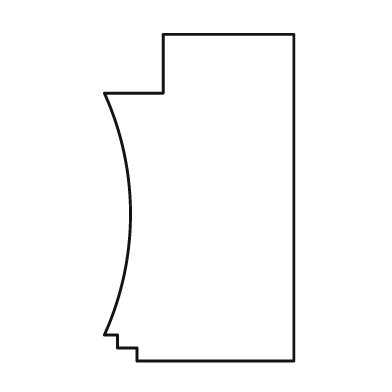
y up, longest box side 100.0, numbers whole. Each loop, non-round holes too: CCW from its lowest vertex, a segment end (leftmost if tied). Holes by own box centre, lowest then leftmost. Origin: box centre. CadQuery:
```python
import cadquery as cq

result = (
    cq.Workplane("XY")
    .moveTo(-19.0, -50.0)
    .lineTo(29.0, -50.0)
    .lineTo(29.0, 50.0)
    .lineTo(-11.0, 50.0)
    .lineTo(-11.0, 32.0)
    .lineTo(-29.0, 32.0)
    .threePointArc((-21.0, -5.0), (-29.0, -42.0))
    .lineTo(-25.0, -42.0)
    .lineTo(-25.0, -46.0)
    .lineTo(-19.0, -46.0)
    .close()
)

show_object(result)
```